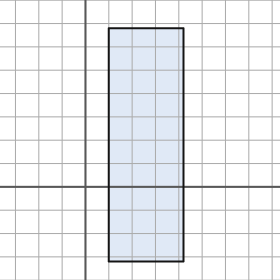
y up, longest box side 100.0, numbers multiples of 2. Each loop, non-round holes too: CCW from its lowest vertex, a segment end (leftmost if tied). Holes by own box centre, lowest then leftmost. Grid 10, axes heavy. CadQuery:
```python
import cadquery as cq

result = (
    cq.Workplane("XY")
    .moveTo(10.0, -32.0)
    .lineTo(42.0, -32.0)
    .lineTo(42.0, 68.0)
    .lineTo(10.0, 68.0)
    .close()
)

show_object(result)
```